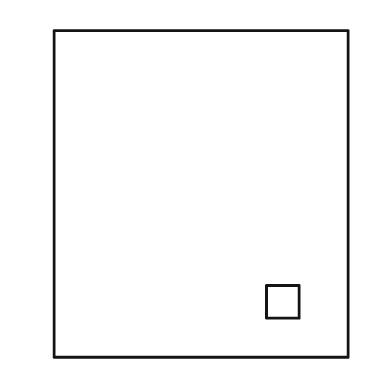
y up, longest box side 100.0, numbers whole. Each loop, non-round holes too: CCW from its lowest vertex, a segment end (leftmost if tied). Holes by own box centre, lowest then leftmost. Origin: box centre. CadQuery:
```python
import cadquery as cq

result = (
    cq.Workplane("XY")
    .moveTo(-45.0, -50.0)
    .lineTo(45.0, -50.0)
    .lineTo(45.0, 50.0)
    .lineTo(-45.0, 50.0)
    .close()
    .moveTo(20.0, -38.0)
    .lineTo(30.0, -38.0)
    .lineTo(30.0, -28.0)
    .lineTo(20.0, -28.0)
    .close()
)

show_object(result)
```